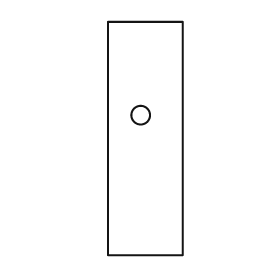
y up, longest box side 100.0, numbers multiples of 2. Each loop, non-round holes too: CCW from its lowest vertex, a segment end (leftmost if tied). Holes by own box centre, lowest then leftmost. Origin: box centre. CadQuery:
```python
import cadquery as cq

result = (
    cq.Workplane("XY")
    .moveTo(-16.0, -50.0)
    .lineTo(16.0, -50.0)
    .lineTo(16.0, 50.0)
    .lineTo(-16.0, 50.0)
    .close()
    .moveTo(-2.0, 10.0)
    .circle(4.0)
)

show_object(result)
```